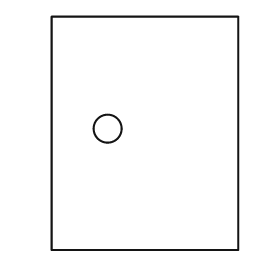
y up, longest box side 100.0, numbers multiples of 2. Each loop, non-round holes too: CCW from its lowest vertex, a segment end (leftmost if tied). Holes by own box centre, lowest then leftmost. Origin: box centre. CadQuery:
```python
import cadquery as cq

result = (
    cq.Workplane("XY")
    .moveTo(-40.0, -50.0)
    .lineTo(40.0, -50.0)
    .lineTo(40.0, 50.0)
    .lineTo(-40.0, 50.0)
    .close()
    .moveTo(-16.0, 2.0)
    .circle(6.0)
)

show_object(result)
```